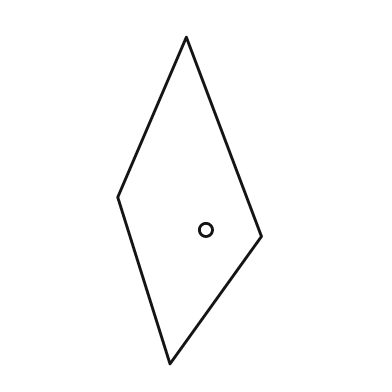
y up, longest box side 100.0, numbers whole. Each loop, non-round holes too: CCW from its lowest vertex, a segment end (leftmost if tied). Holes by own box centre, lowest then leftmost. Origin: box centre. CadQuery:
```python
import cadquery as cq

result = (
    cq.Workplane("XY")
    .moveTo(-6.0, -50.0)
    .lineTo(22.0, -11.0)
    .lineTo(-1.0, 50.0)
    .lineTo(-22.0, 1.0)
    .close()
    .moveTo(5.0, -9.0)
    .circle(2.0)
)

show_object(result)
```